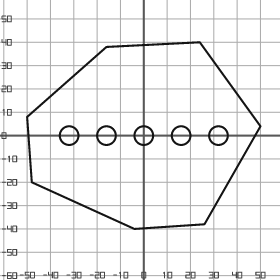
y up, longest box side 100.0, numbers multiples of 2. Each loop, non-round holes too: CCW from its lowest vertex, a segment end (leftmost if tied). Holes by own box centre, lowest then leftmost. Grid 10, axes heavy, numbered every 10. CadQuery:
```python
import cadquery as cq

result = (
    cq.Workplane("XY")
    .moveTo(-4.0, -40.0)
    .lineTo(26.0, -38.0)
    .lineTo(50.0, 4.0)
    .lineTo(24.0, 40.0)
    .lineTo(-16.0, 38.0)
    .lineTo(-50.0, 8.0)
    .lineTo(-48.0, -20.0)
    .close()
    .moveTo(-32.0, 0.0)
    .circle(4.0)
    .moveTo(-16.0, 0.0)
    .circle(4.0)
    .moveTo(0.0, 0.0)
    .circle(4.0)
    .moveTo(16.0, 0.0)
    .circle(4.0)
    .moveTo(32.0, 0.0)
    .circle(4.0)
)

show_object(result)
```